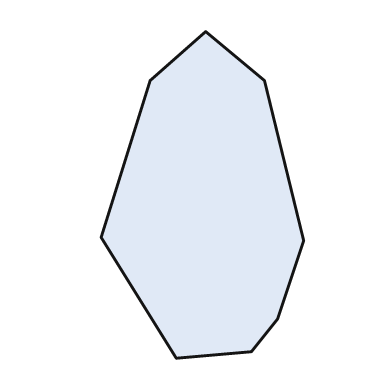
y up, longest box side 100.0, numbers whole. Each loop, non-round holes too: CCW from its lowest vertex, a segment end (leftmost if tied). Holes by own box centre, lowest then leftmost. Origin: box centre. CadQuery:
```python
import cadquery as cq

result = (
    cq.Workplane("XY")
    .moveTo(-8.0, -50.0)
    .lineTo(15.0, -48.0)
    .lineTo(23.0, -38.0)
    .lineTo(31.0, -14.0)
    .lineTo(19.0, 35.0)
    .lineTo(1.0, 50.0)
    .lineTo(-16.0, 35.0)
    .lineTo(-31.0, -13.0)
    .close()
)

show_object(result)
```